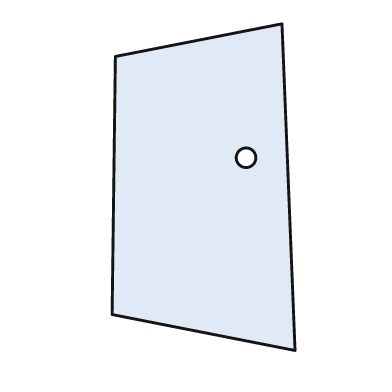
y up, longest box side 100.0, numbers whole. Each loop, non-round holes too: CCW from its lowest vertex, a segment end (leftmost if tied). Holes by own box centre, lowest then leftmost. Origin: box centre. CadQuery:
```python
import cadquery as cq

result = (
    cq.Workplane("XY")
    .moveTo(28.0, -50.0)
    .lineTo(24.0, 50.0)
    .lineTo(-27.0, 40.0)
    .lineTo(-28.0, -39.0)
    .close()
    .moveTo(13.0, 9.0)
    .circle(3.0)
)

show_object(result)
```